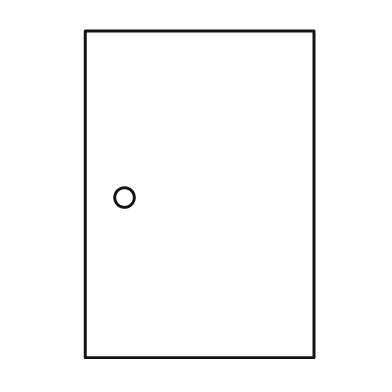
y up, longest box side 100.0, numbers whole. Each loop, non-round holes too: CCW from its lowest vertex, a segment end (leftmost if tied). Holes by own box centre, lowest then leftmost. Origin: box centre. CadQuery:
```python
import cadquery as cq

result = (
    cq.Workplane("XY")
    .moveTo(-35.0, -50.0)
    .lineTo(35.0, -50.0)
    .lineTo(35.0, 50.0)
    .lineTo(-35.0, 50.0)
    .close()
    .moveTo(-23.0, -1.0)
    .circle(3.0)
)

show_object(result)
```